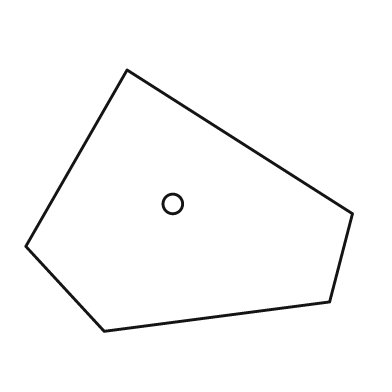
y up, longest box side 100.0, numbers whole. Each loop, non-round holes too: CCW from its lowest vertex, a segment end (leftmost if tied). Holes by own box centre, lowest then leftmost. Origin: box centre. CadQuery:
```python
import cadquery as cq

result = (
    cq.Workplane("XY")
    .moveTo(-26.0, -40.0)
    .lineTo(43.0, -31.0)
    .lineTo(50.0, -4.0)
    .lineTo(-19.0, 40.0)
    .lineTo(-50.0, -14.0)
    .close()
    .moveTo(-5.0, -1.0)
    .circle(3.0)
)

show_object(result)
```